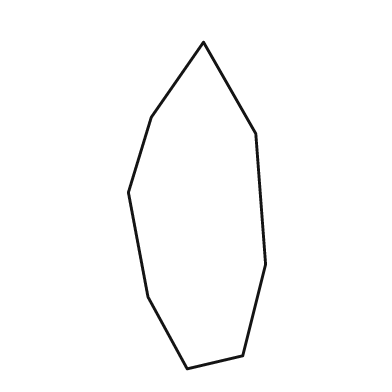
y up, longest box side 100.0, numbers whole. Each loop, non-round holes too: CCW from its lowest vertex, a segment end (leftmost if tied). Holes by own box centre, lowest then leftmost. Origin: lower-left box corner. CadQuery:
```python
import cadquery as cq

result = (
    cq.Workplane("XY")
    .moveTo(18.0, 0.0)
    .lineTo(35.0, 4.0)
    .lineTo(42.0, 32.0)
    .lineTo(39.0, 72.0)
    .lineTo(23.0, 100.0)
    .lineTo(7.0, 77.0)
    .lineTo(0.0, 54.0)
    .lineTo(6.0, 22.0)
    .close()
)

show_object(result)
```